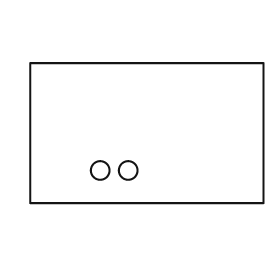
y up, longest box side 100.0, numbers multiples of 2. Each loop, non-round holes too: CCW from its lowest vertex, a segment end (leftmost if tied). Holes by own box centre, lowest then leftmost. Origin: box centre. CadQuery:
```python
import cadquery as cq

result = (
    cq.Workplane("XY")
    .moveTo(-50.0, -30.0)
    .lineTo(50.0, -30.0)
    .lineTo(50.0, 30.0)
    .lineTo(-50.0, 30.0)
    .close()
    .moveTo(-20.0, -16.0)
    .circle(4.0)
    .moveTo(-8.0, -16.0)
    .circle(4.0)
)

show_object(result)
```